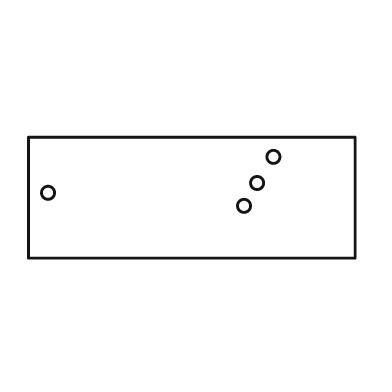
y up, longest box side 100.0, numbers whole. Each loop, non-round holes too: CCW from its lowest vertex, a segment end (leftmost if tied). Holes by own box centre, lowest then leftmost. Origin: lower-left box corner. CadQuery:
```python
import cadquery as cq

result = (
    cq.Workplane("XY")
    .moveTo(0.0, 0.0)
    .lineTo(100.0, 0.0)
    .lineTo(100.0, 37.0)
    .lineTo(0.0, 37.0)
    .close()
    .moveTo(66.0, 16.0)
    .circle(2.0)
    .moveTo(6.0, 20.0)
    .circle(2.0)
    .moveTo(70.0, 23.0)
    .circle(2.0)
    .moveTo(75.0, 31.0)
    .circle(2.0)
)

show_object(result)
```